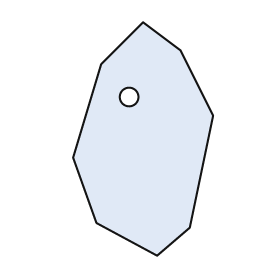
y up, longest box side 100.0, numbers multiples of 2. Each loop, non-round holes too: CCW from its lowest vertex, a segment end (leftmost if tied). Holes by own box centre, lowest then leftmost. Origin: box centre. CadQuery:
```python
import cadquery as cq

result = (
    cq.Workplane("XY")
    .moveTo(6.0, -50.0)
    .lineTo(20.0, -38.0)
    .lineTo(30.0, 10.0)
    .lineTo(16.0, 38.0)
    .lineTo(0.0, 50.0)
    .lineTo(-18.0, 32.0)
    .lineTo(-30.0, -8.0)
    .lineTo(-20.0, -36.0)
    .close()
    .moveTo(-6.0, 18.0)
    .circle(4.0)
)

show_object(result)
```